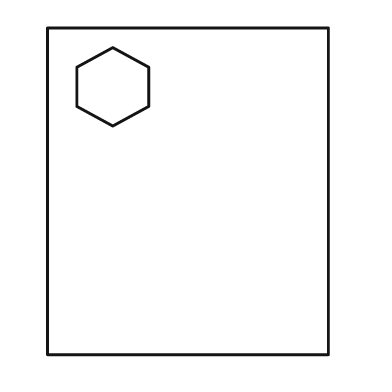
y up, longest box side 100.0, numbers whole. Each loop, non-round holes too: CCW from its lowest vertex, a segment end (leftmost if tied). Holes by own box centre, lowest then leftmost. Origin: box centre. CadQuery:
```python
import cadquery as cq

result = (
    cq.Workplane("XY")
    .moveTo(-43.0, -50.0)
    .lineTo(43.0, -50.0)
    .lineTo(43.0, 50.0)
    .lineTo(-43.0, 50.0)
    .close()
    .moveTo(-23.0, 20.0)
    .lineTo(-12.0, 26.0)
    .lineTo(-12.0, 38.0)
    .lineTo(-23.0, 44.0)
    .lineTo(-34.0, 38.0)
    .lineTo(-34.0, 26.0)
    .close()
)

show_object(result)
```